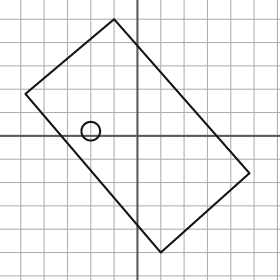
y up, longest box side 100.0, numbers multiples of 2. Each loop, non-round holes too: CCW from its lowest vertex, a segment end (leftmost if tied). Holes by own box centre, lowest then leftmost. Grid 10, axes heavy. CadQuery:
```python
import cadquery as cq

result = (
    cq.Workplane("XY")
    .moveTo(10.0, -50.0)
    .lineTo(48.0, -16.0)
    .lineTo(-10.0, 50.0)
    .lineTo(-48.0, 18.0)
    .close()
    .moveTo(-20.0, 2.0)
    .circle(4.0)
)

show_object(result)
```